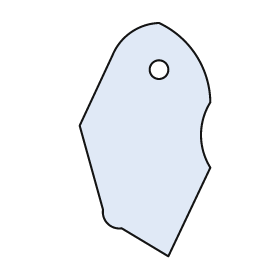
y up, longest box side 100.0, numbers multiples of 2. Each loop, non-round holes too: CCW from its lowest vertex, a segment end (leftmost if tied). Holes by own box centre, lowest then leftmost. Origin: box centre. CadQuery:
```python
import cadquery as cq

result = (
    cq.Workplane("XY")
    .moveTo(10.0, -50.0)
    .lineTo(28.0, -12.0)
    .threePointArc((24.0, 2.0), (28.0, 16.0))
    .threePointArc((22.0, 36.0), (6.0, 50.0))
    .threePointArc((-6.0, 46.0), (-14.0, 36.0))
    .lineTo(-28.0, 6.0)
    .lineTo(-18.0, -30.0)
    .threePointArc((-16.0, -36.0), (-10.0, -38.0))
    .close()
    .moveTo(6.0, 30.0)
    .circle(4.0)
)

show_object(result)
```